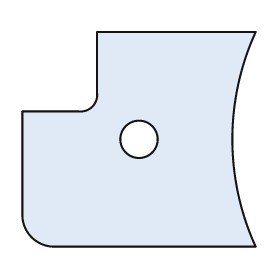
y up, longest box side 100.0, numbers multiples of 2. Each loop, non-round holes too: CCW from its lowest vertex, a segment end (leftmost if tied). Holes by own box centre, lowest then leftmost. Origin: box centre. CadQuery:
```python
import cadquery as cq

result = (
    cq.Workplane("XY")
    .moveTo(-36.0, -46.0)
    .lineTo(50.0, -46.0)
    .threePointArc((40.0, 0.0), (50.0, 46.0))
    .lineTo(-18.0, 46.0)
    .lineTo(-18.0, 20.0)
    .threePointArc((-20.0, 14.0), (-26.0, 12.0))
    .lineTo(-50.0, 12.0)
    .lineTo(-50.0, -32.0)
    .threePointArc((-46.0, -42.0), (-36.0, -46.0))
    .close()
    .moveTo(0.0, 0.0)
    .circle(8.0)
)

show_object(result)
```